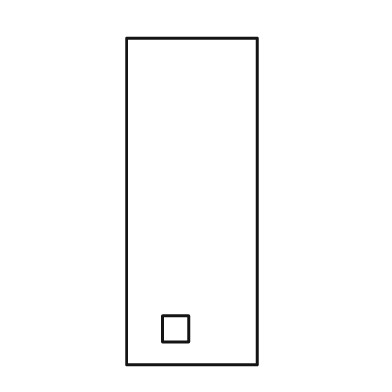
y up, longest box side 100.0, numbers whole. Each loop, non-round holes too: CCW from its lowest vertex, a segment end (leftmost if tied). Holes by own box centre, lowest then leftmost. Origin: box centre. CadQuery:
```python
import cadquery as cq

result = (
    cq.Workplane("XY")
    .moveTo(-20.0, -50.0)
    .lineTo(20.0, -50.0)
    .lineTo(20.0, 50.0)
    .lineTo(-20.0, 50.0)
    .close()
    .moveTo(-9.0, -43.0)
    .lineTo(-1.0, -43.0)
    .lineTo(-1.0, -35.0)
    .lineTo(-9.0, -35.0)
    .close()
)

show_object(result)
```